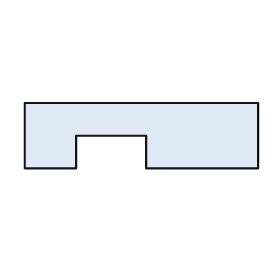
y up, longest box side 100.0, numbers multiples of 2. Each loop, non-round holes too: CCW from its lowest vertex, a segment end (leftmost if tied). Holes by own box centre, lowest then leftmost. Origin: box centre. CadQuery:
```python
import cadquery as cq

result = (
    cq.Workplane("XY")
    .moveTo(-50.0, -14.0)
    .lineTo(-28.0, -14.0)
    .lineTo(-28.0, 0.0)
    .lineTo(2.0, 0.0)
    .lineTo(2.0, -14.0)
    .lineTo(50.0, -14.0)
    .lineTo(50.0, 14.0)
    .lineTo(-50.0, 14.0)
    .close()
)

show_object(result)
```